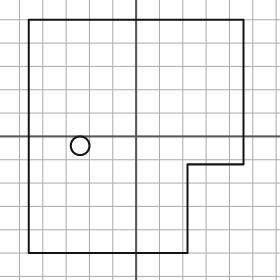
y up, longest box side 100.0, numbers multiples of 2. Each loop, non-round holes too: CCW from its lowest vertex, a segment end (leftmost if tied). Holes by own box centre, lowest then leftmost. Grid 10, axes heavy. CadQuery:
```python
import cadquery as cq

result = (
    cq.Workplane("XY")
    .moveTo(-46.0, -50.0)
    .lineTo(22.0, -50.0)
    .lineTo(22.0, -12.0)
    .lineTo(46.0, -12.0)
    .lineTo(46.0, 50.0)
    .lineTo(-46.0, 50.0)
    .close()
    .moveTo(-24.0, -4.0)
    .circle(4.0)
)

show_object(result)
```